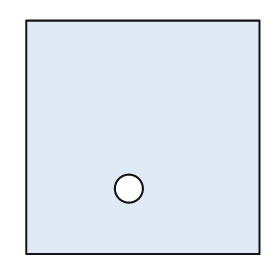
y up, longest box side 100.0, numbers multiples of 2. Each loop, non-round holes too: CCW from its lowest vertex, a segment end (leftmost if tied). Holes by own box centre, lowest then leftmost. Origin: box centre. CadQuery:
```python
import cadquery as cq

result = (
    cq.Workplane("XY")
    .moveTo(-50.0, -50.0)
    .lineTo(50.0, -50.0)
    .lineTo(50.0, 50.0)
    .lineTo(-50.0, 50.0)
    .close()
    .moveTo(-6.0, -22.0)
    .circle(6.0)
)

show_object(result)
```